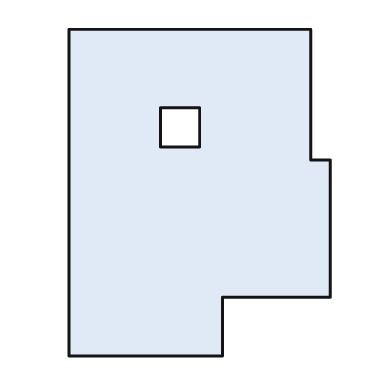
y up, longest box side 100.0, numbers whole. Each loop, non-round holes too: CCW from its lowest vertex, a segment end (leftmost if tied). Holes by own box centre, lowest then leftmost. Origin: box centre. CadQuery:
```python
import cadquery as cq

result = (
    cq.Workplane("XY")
    .moveTo(-40.0, -50.0)
    .lineTo(7.0, -50.0)
    .lineTo(7.0, -32.0)
    .lineTo(40.0, -32.0)
    .lineTo(40.0, 10.0)
    .lineTo(34.0, 10.0)
    .lineTo(34.0, 50.0)
    .lineTo(-40.0, 50.0)
    .close()
    .moveTo(-12.0, 14.0)
    .lineTo(0.0, 14.0)
    .lineTo(0.0, 26.0)
    .lineTo(-12.0, 26.0)
    .close()
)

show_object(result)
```